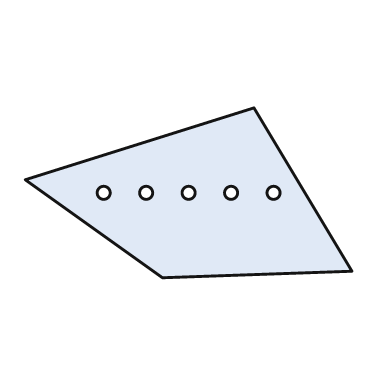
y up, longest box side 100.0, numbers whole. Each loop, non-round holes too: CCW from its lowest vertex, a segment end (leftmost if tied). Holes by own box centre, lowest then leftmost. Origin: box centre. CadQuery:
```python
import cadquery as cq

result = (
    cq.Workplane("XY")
    .moveTo(-8.0, -26.0)
    .lineTo(50.0, -24.0)
    .lineTo(20.0, 26.0)
    .lineTo(-50.0, 4.0)
    .close()
    .moveTo(-26.0, 0.0)
    .circle(2.0)
    .moveTo(-13.0, 0.0)
    .circle(2.0)
    .moveTo(0.0, 0.0)
    .circle(2.0)
    .moveTo(13.0, 0.0)
    .circle(2.0)
    .moveTo(26.0, 0.0)
    .circle(2.0)
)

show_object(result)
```